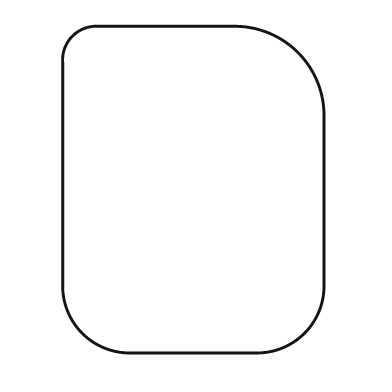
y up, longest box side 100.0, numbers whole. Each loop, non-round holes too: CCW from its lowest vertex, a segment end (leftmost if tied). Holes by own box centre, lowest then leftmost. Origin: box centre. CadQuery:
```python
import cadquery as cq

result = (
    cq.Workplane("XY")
    .moveTo(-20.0, -50.0)
    .lineTo(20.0, -50.0)
    .threePointArc((34.0, -44.0), (40.0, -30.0))
    .lineTo(40.0, 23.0)
    .threePointArc((32.0, 42.0), (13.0, 50.0))
    .lineTo(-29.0, 50.0)
    .threePointArc((-37.0, 47.0), (-40.0, 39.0))
    .lineTo(-40.0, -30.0)
    .threePointArc((-34.0, -44.0), (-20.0, -50.0))
    .close()
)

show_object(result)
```